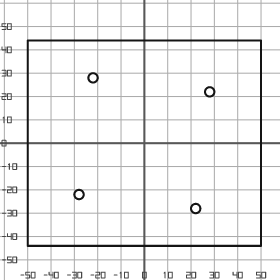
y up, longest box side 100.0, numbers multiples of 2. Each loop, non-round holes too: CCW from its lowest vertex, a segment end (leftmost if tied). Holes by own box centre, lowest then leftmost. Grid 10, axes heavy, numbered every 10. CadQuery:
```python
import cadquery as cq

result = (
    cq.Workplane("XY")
    .moveTo(-50.0, -44.0)
    .lineTo(50.0, -44.0)
    .lineTo(50.0, 44.0)
    .lineTo(-50.0, 44.0)
    .close()
    .moveTo(22.0, -28.0)
    .circle(2.0)
    .moveTo(-28.0, -22.0)
    .circle(2.0)
    .moveTo(28.0, 22.0)
    .circle(2.0)
    .moveTo(-22.0, 28.0)
    .circle(2.0)
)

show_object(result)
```